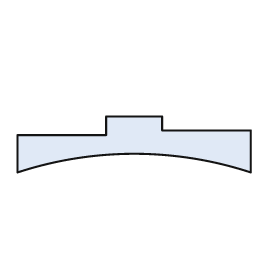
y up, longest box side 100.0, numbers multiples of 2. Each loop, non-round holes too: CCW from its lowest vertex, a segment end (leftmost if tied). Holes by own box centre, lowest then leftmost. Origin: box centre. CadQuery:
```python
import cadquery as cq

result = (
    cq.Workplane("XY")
    .moveTo(-50.0, -12.0)
    .threePointArc((0.0, -4.0), (50.0, -12.0))
    .lineTo(50.0, 6.0)
    .lineTo(12.0, 6.0)
    .lineTo(12.0, 12.0)
    .lineTo(-12.0, 12.0)
    .lineTo(-12.0, 4.0)
    .lineTo(-50.0, 4.0)
    .close()
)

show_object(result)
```